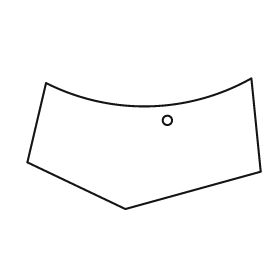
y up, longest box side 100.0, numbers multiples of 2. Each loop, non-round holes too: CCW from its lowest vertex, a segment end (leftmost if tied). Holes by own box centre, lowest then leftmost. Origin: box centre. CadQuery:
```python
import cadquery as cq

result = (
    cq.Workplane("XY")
    .moveTo(-8.0, -28.0)
    .lineTo(50.0, -12.0)
    .lineTo(46.0, 28.0)
    .threePointArc((2.0, 16.0), (-42.0, 26.0))
    .lineTo(-50.0, -8.0)
    .close()
    .moveTo(10.0, 10.0)
    .circle(2.0)
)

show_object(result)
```